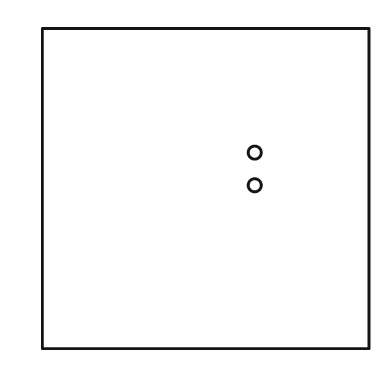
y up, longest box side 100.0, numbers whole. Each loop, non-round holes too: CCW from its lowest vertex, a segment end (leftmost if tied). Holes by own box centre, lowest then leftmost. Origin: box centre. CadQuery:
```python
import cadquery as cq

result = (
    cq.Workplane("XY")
    .moveTo(-50.0, -49.0)
    .lineTo(50.0, -49.0)
    .lineTo(50.0, 49.0)
    .lineTo(-50.0, 49.0)
    .close()
    .moveTo(15.0, 1.0)
    .circle(2.0)
    .moveTo(15.0, 11.0)
    .circle(2.0)
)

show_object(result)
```